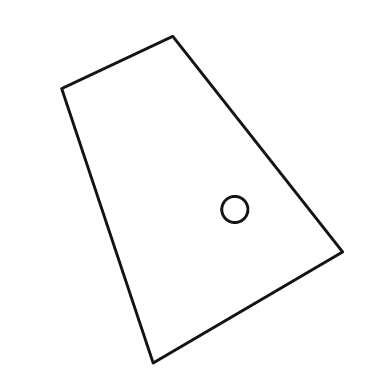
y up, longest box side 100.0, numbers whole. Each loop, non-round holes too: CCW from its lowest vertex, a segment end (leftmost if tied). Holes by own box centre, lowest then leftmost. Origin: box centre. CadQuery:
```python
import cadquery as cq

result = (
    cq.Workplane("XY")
    .moveTo(-15.0, -50.0)
    .lineTo(43.0, -16.0)
    .lineTo(-9.0, 50.0)
    .lineTo(-43.0, 34.0)
    .close()
    .moveTo(10.0, -3.0)
    .circle(4.0)
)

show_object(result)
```